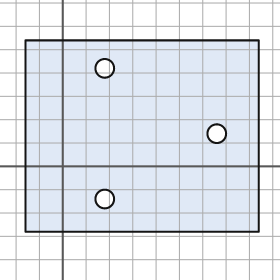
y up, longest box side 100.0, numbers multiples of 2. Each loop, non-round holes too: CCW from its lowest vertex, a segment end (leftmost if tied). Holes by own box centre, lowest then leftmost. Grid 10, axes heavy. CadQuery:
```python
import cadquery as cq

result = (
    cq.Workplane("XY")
    .moveTo(-16.0, -28.0)
    .lineTo(84.0, -28.0)
    .lineTo(84.0, 54.0)
    .lineTo(-16.0, 54.0)
    .close()
    .moveTo(18.0, -14.0)
    .circle(4.0)
    .moveTo(66.0, 14.0)
    .circle(4.0)
    .moveTo(18.0, 42.0)
    .circle(4.0)
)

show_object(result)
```